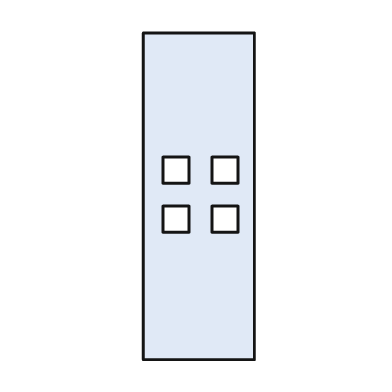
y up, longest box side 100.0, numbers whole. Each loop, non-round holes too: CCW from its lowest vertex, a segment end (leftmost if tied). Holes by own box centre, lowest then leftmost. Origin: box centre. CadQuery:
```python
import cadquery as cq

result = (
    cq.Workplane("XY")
    .moveTo(-17.0, -50.0)
    .lineTo(17.0, -50.0)
    .lineTo(17.0, 50.0)
    .lineTo(-17.0, 50.0)
    .close()
    .moveTo(-11.0, -11.0)
    .lineTo(-3.0, -11.0)
    .lineTo(-3.0, -3.0)
    .lineTo(-11.0, -3.0)
    .close()
    .moveTo(4.0, -11.0)
    .lineTo(12.0, -11.0)
    .lineTo(12.0, -3.0)
    .lineTo(4.0, -3.0)
    .close()
    .moveTo(-11.0, 4.0)
    .lineTo(-3.0, 4.0)
    .lineTo(-3.0, 12.0)
    .lineTo(-11.0, 12.0)
    .close()
    .moveTo(4.0, 4.0)
    .lineTo(12.0, 4.0)
    .lineTo(12.0, 12.0)
    .lineTo(4.0, 12.0)
    .close()
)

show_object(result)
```